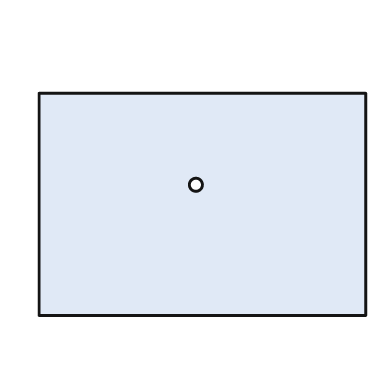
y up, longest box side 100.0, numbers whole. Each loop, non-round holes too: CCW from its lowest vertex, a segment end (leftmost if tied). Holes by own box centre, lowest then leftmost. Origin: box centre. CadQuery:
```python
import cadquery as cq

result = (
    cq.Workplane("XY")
    .moveTo(-50.0, -34.0)
    .lineTo(50.0, -34.0)
    .lineTo(50.0, 34.0)
    .lineTo(-50.0, 34.0)
    .close()
    .moveTo(-2.0, 6.0)
    .circle(2.0)
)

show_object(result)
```